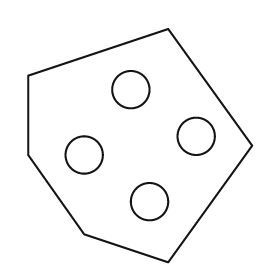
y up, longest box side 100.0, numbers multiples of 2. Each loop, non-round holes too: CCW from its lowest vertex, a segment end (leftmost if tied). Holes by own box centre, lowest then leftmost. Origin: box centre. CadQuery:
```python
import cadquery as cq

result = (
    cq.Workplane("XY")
    .moveTo(12.0, -50.0)
    .lineTo(48.0, 0.0)
    .lineTo(12.0, 50.0)
    .lineTo(-48.0, 30.0)
    .lineTo(-48.0, -4.0)
    .lineTo(-24.0, -38.0)
    .close()
    .moveTo(4.0, -24.0)
    .circle(8.0)
    .moveTo(-24.0, -4.0)
    .circle(8.0)
    .moveTo(24.0, 4.0)
    .circle(8.0)
    .moveTo(-4.0, 24.0)
    .circle(8.0)
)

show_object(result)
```